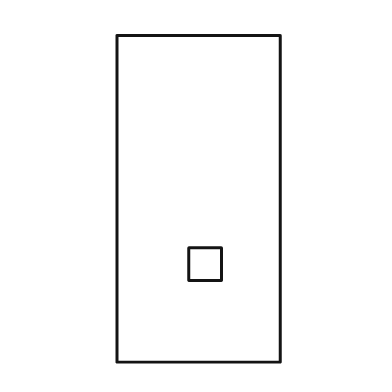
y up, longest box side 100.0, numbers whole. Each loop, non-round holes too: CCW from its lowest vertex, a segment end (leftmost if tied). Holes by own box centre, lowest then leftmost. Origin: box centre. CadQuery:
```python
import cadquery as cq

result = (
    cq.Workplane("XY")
    .moveTo(-25.0, -50.0)
    .lineTo(25.0, -50.0)
    .lineTo(25.0, 50.0)
    .lineTo(-25.0, 50.0)
    .close()
    .moveTo(-3.0, -25.0)
    .lineTo(7.0, -25.0)
    .lineTo(7.0, -15.0)
    .lineTo(-3.0, -15.0)
    .close()
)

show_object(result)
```